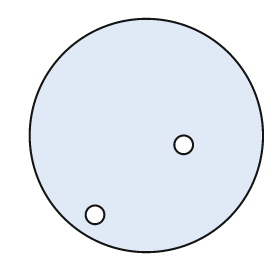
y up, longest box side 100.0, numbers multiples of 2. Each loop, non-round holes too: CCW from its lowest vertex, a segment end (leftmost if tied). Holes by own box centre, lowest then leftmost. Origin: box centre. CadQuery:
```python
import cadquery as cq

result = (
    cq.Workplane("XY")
    .moveTo(0.0, 0.0)
    .circle(50.0)
    .moveTo(-22.0, -34.0)
    .circle(4.0)
    .moveTo(16.0, -4.0)
    .circle(4.0)
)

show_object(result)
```